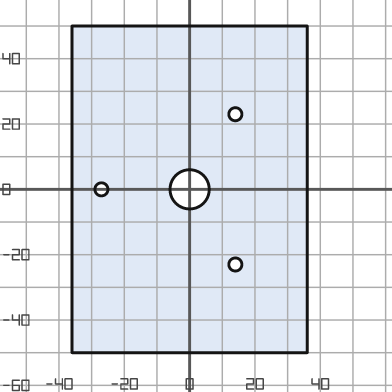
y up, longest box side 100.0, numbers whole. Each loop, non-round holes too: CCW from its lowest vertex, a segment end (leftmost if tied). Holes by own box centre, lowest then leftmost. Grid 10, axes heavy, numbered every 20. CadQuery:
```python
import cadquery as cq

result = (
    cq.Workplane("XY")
    .moveTo(-36.0, -50.0)
    .lineTo(36.0, -50.0)
    .lineTo(36.0, 50.0)
    .lineTo(-36.0, 50.0)
    .close()
    .moveTo(14.0, -23.0)
    .circle(2.0)
    .moveTo(-27.0, 0.0)
    .circle(2.0)
    .moveTo(0.0, 0.0)
    .circle(6.0)
    .moveTo(14.0, 23.0)
    .circle(2.0)
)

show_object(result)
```